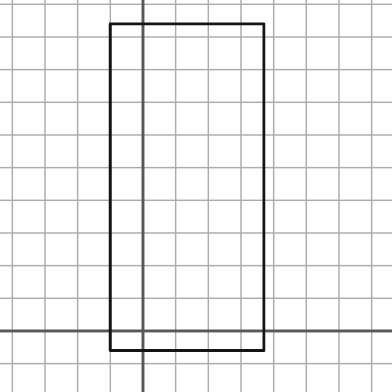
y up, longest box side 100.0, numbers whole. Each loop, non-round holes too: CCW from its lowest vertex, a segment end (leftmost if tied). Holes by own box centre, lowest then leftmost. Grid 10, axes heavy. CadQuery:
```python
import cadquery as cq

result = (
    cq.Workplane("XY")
    .moveTo(-10.0, -6.0)
    .lineTo(37.0, -6.0)
    .lineTo(37.0, 94.0)
    .lineTo(-10.0, 94.0)
    .close()
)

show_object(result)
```